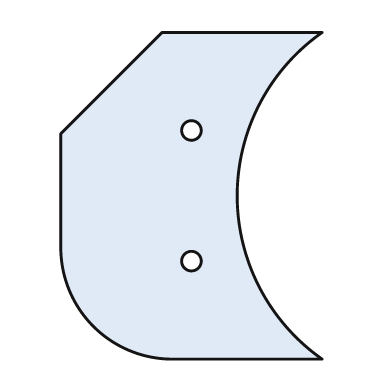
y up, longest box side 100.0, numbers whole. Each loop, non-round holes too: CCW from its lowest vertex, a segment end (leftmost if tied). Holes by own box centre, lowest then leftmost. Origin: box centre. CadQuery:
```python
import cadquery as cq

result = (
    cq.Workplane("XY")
    .moveTo(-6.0, -50.0)
    .lineTo(40.0, -50.0)
    .threePointArc((14.0, 0.0), (40.0, 50.0))
    .lineTo(-9.0, 50.0)
    .lineTo(-40.0, 19.0)
    .lineTo(-40.0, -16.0)
    .threePointArc((-30.0, -40.0), (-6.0, -50.0))
    .close()
    .moveTo(0.0, -20.0)
    .circle(3.0)
    .moveTo(0.0, 20.0)
    .circle(3.0)
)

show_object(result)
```